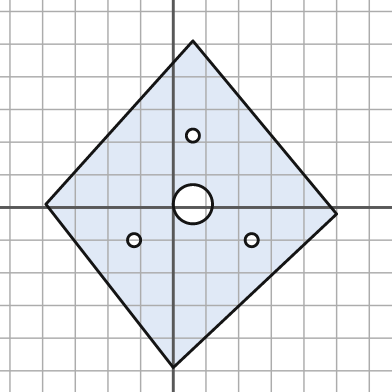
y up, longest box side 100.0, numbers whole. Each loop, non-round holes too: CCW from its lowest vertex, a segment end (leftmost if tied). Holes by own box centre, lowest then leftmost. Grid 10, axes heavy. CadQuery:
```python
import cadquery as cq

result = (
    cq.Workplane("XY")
    .moveTo(0.0, -49.0)
    .lineTo(50.0, -2.0)
    .lineTo(6.0, 51.0)
    .lineTo(-39.0, 1.0)
    .close()
    .moveTo(-12.0, -10.0)
    .circle(2.0)
    .moveTo(24.0, -10.0)
    .circle(2.0)
    .moveTo(6.0, 1.0)
    .circle(6.0)
    .moveTo(6.0, 22.0)
    .circle(2.0)
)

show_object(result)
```